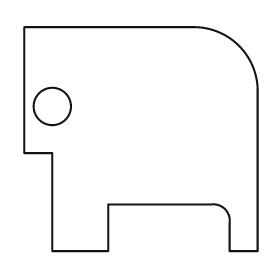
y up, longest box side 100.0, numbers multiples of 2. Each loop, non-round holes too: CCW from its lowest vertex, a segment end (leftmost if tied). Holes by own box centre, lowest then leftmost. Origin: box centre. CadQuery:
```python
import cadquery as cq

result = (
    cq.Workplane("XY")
    .moveTo(-38.0, -48.0)
    .lineTo(-14.0, -48.0)
    .lineTo(-14.0, -28.0)
    .lineTo(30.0, -28.0)
    .threePointArc((36.0, -30.0), (38.0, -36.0))
    .lineTo(38.0, -48.0)
    .lineTo(50.0, -48.0)
    .lineTo(50.0, 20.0)
    .threePointArc((42.0, 40.0), (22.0, 48.0))
    .lineTo(-50.0, 48.0)
    .lineTo(-50.0, -6.0)
    .lineTo(-38.0, -6.0)
    .close()
    .moveTo(-38.0, 14.0)
    .circle(8.0)
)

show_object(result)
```